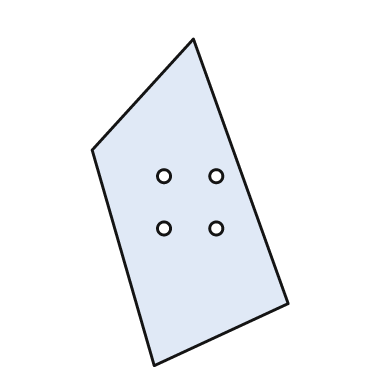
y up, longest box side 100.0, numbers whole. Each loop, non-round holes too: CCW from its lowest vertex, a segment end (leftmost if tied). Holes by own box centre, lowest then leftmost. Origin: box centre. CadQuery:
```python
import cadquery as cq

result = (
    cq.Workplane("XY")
    .moveTo(-11.0, -50.0)
    .lineTo(30.0, -31.0)
    .lineTo(1.0, 50.0)
    .lineTo(-30.0, 16.0)
    .close()
    .moveTo(-8.0, -8.0)
    .circle(2.0)
    .moveTo(8.0, -8.0)
    .circle(2.0)
    .moveTo(-8.0, 8.0)
    .circle(2.0)
    .moveTo(8.0, 8.0)
    .circle(2.0)
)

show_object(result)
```